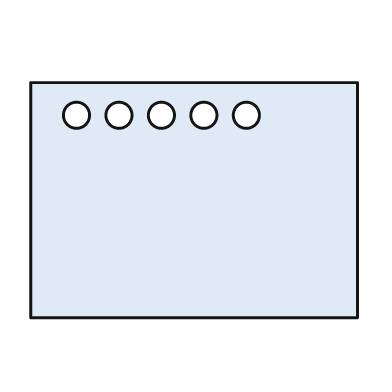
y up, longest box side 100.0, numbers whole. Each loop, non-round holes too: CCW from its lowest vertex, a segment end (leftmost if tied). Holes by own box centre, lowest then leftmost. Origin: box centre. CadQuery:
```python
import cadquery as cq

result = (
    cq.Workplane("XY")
    .moveTo(-50.0, -36.0)
    .lineTo(50.0, -36.0)
    .lineTo(50.0, 36.0)
    .lineTo(-50.0, 36.0)
    .close()
    .moveTo(-36.0, 26.0)
    .circle(4.0)
    .moveTo(-23.0, 26.0)
    .circle(4.0)
    .moveTo(-10.0, 26.0)
    .circle(4.0)
    .moveTo(3.0, 26.0)
    .circle(4.0)
    .moveTo(16.0, 26.0)
    .circle(4.0)
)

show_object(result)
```